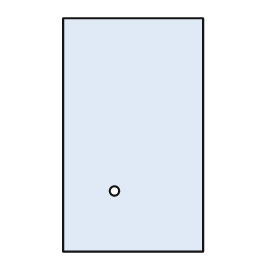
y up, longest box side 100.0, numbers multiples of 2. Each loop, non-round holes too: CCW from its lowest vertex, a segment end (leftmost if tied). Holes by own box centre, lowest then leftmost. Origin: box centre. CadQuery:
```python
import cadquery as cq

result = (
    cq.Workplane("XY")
    .moveTo(-30.0, -50.0)
    .lineTo(30.0, -50.0)
    .lineTo(30.0, 50.0)
    .lineTo(-30.0, 50.0)
    .close()
    .moveTo(-8.0, -24.0)
    .circle(2.0)
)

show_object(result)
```